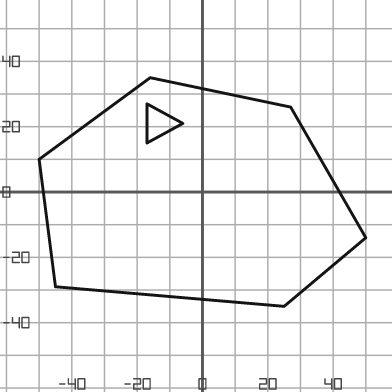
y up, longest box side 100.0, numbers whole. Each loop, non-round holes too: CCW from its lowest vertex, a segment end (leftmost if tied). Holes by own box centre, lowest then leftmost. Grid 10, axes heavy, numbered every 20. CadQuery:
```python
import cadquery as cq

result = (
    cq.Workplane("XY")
    .moveTo(25.0, -35.0)
    .lineTo(50.0, -14.0)
    .lineTo(27.0, 26.0)
    .lineTo(-16.0, 35.0)
    .lineTo(-50.0, 10.0)
    .lineTo(-45.0, -29.0)
    .close()
    .moveTo(-17.0, 15.0)
    .lineTo(-6.0, 21.0)
    .lineTo(-17.0, 27.0)
    .close()
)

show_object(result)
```